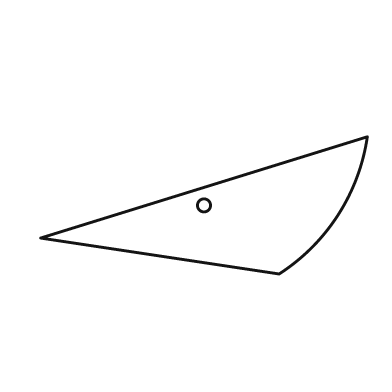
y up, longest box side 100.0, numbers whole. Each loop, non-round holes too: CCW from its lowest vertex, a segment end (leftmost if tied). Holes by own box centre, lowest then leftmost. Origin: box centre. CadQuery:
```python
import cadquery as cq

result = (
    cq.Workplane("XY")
    .moveTo(23.0, -21.0)
    .threePointArc((41.0, -3.0), (50.0, 21.0))
    .lineTo(-50.0, -10.0)
    .close()
    .moveTo(0.0, 0.0)
    .circle(2.0)
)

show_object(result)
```